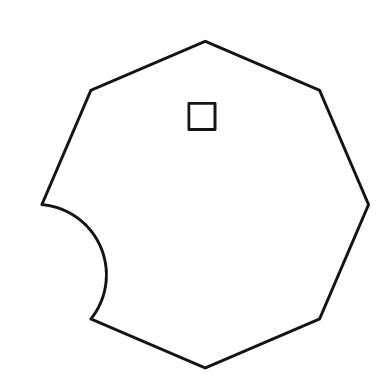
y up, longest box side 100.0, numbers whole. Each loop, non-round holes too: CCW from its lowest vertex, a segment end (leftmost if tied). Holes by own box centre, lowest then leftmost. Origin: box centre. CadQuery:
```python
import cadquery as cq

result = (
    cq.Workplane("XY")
    .moveTo(0.0, -50.0)
    .lineTo(35.0, -35.0)
    .lineTo(50.0, 0.0)
    .lineTo(35.0, 35.0)
    .lineTo(0.0, 50.0)
    .lineTo(-35.0, 35.0)
    .lineTo(-50.0, 0.0)
    .threePointArc((-32.0, -13.0), (-35.0, -35.0))
    .close()
    .moveTo(-5.0, 23.0)
    .lineTo(3.0, 23.0)
    .lineTo(3.0, 31.0)
    .lineTo(-5.0, 31.0)
    .close()
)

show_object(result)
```